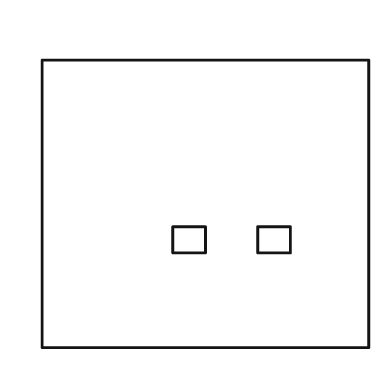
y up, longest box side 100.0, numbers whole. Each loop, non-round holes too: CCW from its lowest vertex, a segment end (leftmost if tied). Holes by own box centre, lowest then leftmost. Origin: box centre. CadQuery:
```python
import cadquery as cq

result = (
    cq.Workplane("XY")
    .moveTo(-50.0, -44.0)
    .lineTo(50.0, -44.0)
    .lineTo(50.0, 44.0)
    .lineTo(-50.0, 44.0)
    .close()
    .moveTo(-10.0, -15.0)
    .lineTo(0.0, -15.0)
    .lineTo(0.0, -7.0)
    .lineTo(-10.0, -7.0)
    .close()
    .moveTo(16.0, -15.0)
    .lineTo(26.0, -15.0)
    .lineTo(26.0, -7.0)
    .lineTo(16.0, -7.0)
    .close()
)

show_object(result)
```